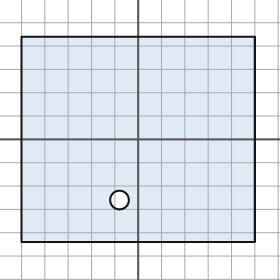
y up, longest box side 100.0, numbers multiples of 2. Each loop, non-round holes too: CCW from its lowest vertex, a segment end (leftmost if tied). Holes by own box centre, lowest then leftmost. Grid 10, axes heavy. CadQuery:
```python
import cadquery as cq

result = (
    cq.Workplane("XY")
    .moveTo(-50.0, -44.0)
    .lineTo(50.0, -44.0)
    .lineTo(50.0, 44.0)
    .lineTo(-50.0, 44.0)
    .close()
    .moveTo(-8.0, -26.0)
    .circle(4.0)
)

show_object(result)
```